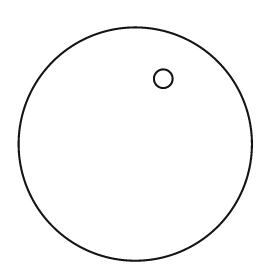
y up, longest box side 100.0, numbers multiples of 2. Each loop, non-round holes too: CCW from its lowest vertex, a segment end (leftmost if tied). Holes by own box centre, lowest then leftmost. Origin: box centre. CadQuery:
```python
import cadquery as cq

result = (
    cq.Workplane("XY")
    .moveTo(0.0, 0.0)
    .circle(50.0)
    .moveTo(12.0, 28.0)
    .circle(4.0)
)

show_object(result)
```